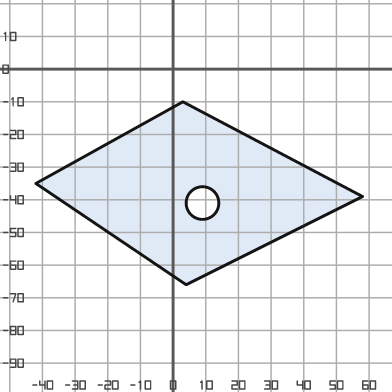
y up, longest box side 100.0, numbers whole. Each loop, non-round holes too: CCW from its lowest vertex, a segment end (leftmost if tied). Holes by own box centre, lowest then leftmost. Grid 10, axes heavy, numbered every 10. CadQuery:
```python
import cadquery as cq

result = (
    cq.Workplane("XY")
    .moveTo(4.0, -66.0)
    .lineTo(58.0, -39.0)
    .lineTo(3.0, -10.0)
    .lineTo(-42.0, -35.0)
    .close()
    .moveTo(9.0, -41.0)
    .circle(5.0)
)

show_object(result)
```